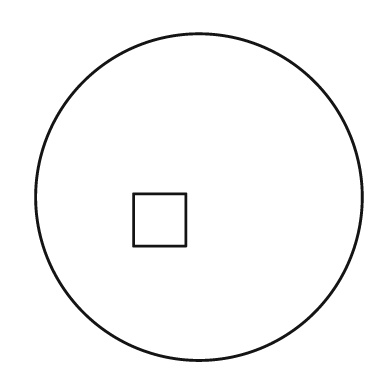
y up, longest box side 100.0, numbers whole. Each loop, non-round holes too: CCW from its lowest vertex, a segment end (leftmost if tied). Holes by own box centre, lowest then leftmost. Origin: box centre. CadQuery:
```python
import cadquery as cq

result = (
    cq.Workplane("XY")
    .moveTo(0.0, 0.0)
    .circle(50.0)
    .moveTo(-20.0, -15.0)
    .lineTo(-4.0, -15.0)
    .lineTo(-4.0, 1.0)
    .lineTo(-20.0, 1.0)
    .close()
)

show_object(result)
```